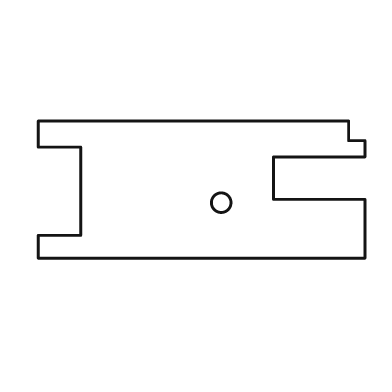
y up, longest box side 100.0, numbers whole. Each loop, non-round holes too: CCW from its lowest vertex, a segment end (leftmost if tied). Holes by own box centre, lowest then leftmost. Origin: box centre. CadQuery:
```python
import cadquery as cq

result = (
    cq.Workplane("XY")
    .moveTo(-50.0, -21.0)
    .lineTo(50.0, -21.0)
    .lineTo(50.0, -3.0)
    .lineTo(22.0, -3.0)
    .lineTo(22.0, 10.0)
    .lineTo(50.0, 10.0)
    .lineTo(50.0, 15.0)
    .lineTo(45.0, 15.0)
    .lineTo(45.0, 21.0)
    .lineTo(-50.0, 21.0)
    .lineTo(-50.0, 13.0)
    .lineTo(-37.0, 13.0)
    .lineTo(-37.0, -14.0)
    .lineTo(-50.0, -14.0)
    .close()
    .moveTo(6.0, -4.0)
    .circle(3.0)
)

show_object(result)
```